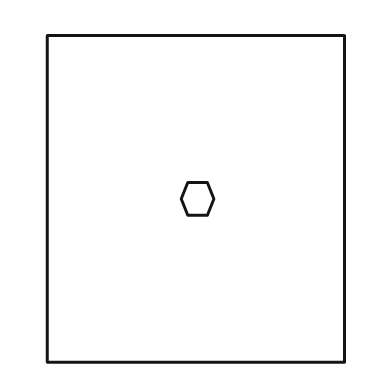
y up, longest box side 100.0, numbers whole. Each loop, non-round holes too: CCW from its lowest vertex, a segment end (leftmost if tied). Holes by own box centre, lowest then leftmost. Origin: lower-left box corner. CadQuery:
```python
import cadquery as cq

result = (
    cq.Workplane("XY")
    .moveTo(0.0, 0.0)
    .lineTo(91.0, 0.0)
    .lineTo(91.0, 100.0)
    .lineTo(0.0, 100.0)
    .close()
    .moveTo(43.0, 45.0)
    .lineTo(49.0, 45.0)
    .lineTo(51.0, 50.0)
    .lineTo(49.0, 55.0)
    .lineTo(43.0, 55.0)
    .lineTo(41.0, 50.0)
    .close()
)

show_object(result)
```